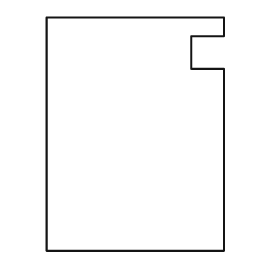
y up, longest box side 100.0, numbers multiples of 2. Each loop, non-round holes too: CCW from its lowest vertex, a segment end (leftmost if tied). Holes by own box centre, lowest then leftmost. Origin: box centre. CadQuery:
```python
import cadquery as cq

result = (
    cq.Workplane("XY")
    .moveTo(-38.0, -50.0)
    .lineTo(38.0, -50.0)
    .lineTo(38.0, 28.0)
    .lineTo(24.0, 28.0)
    .lineTo(24.0, 42.0)
    .lineTo(38.0, 42.0)
    .lineTo(38.0, 50.0)
    .lineTo(-38.0, 50.0)
    .close()
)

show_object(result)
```